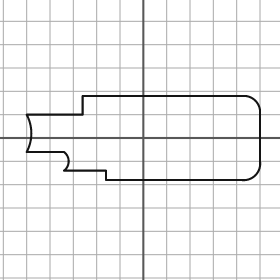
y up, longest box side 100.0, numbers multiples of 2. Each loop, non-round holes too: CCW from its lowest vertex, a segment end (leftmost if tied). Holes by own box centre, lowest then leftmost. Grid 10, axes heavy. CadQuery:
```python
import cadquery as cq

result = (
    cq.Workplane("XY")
    .moveTo(-16.0, -18.0)
    .lineTo(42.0, -18.0)
    .threePointArc((48.0, -16.0), (50.0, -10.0))
    .lineTo(50.0, 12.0)
    .threePointArc((48.0, 16.0), (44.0, 18.0))
    .lineTo(-26.0, 18.0)
    .lineTo(-26.0, 10.0)
    .lineTo(-50.0, 10.0)
    .threePointArc((-48.0, 2.0), (-50.0, -6.0))
    .lineTo(-34.0, -6.0)
    .threePointArc((-32.0, -10.0), (-34.0, -14.0))
    .lineTo(-16.0, -14.0)
    .close()
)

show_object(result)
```